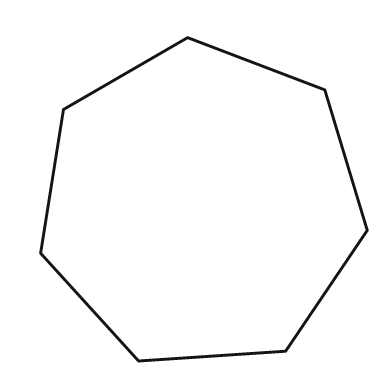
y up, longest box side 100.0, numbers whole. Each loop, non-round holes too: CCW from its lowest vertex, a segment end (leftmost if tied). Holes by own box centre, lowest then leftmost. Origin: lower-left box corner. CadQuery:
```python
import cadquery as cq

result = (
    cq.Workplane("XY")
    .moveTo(30.0, 0.0)
    .lineTo(75.0, 3.0)
    .lineTo(100.0, 40.0)
    .lineTo(87.0, 83.0)
    .lineTo(45.0, 99.0)
    .lineTo(7.0, 77.0)
    .lineTo(0.0, 33.0)
    .close()
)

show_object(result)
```